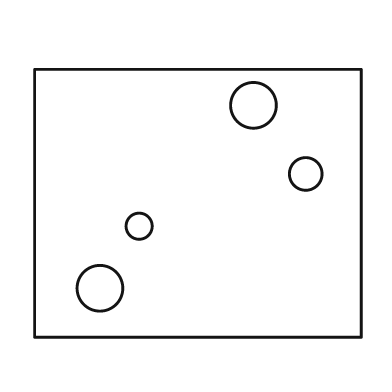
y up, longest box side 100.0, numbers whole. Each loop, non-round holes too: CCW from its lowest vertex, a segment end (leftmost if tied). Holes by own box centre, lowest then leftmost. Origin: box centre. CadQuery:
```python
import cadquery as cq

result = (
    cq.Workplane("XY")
    .moveTo(-50.0, -41.0)
    .lineTo(50.0, -41.0)
    .lineTo(50.0, 41.0)
    .lineTo(-50.0, 41.0)
    .close()
    .moveTo(-30.0, -26.0)
    .circle(7.0)
    .moveTo(-18.0, -7.0)
    .circle(4.0)
    .moveTo(33.0, 9.0)
    .circle(5.0)
    .moveTo(17.0, 30.0)
    .circle(7.0)
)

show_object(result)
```